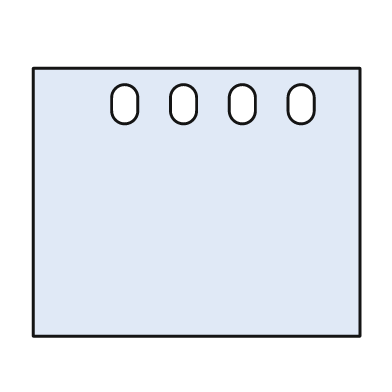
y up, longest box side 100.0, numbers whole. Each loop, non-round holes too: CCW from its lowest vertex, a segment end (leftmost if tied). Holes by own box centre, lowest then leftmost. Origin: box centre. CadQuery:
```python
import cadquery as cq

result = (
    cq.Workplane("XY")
    .moveTo(-50.0, -41.0)
    .lineTo(50.0, -41.0)
    .lineTo(50.0, 41.0)
    .lineTo(-50.0, 41.0)
    .close()
    .moveTo(-26.0, 28.0)
    .threePointArc((-22.0, 24.0), (-18.0, 28.0))
    .lineTo(-18.0, 32.0)
    .threePointArc((-22.0, 36.0), (-26.0, 32.0))
    .close()
    .moveTo(-8.0, 28.0)
    .threePointArc((-4.0, 24.0), (0.0, 28.0))
    .lineTo(0.0, 32.0)
    .threePointArc((-4.0, 36.0), (-8.0, 32.0))
    .close()
    .moveTo(10.0, 28.0)
    .threePointArc((14.0, 24.0), (18.0, 28.0))
    .lineTo(18.0, 32.0)
    .threePointArc((14.0, 36.0), (10.0, 32.0))
    .close()
    .moveTo(28.0, 28.0)
    .threePointArc((32.0, 24.0), (36.0, 28.0))
    .lineTo(36.0, 32.0)
    .threePointArc((32.0, 36.0), (28.0, 32.0))
    .close()
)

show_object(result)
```